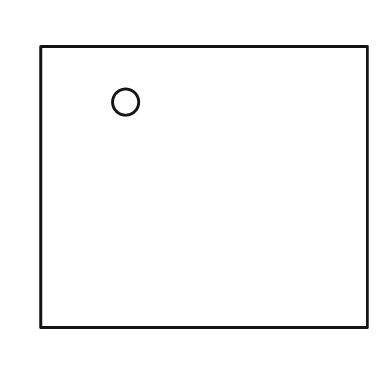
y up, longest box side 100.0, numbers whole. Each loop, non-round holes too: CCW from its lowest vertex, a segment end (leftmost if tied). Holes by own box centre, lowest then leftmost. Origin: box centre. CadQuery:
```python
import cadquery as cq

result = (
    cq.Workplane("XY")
    .moveTo(-50.0, -43.0)
    .lineTo(50.0, -43.0)
    .lineTo(50.0, 43.0)
    .lineTo(-50.0, 43.0)
    .close()
    .moveTo(-24.0, 26.0)
    .circle(4.0)
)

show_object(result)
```